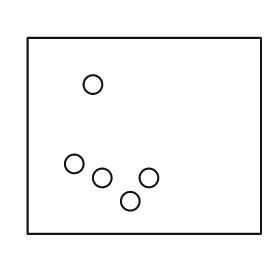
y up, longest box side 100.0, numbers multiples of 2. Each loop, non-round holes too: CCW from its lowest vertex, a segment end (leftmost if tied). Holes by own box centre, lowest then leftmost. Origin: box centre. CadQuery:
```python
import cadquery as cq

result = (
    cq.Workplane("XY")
    .moveTo(-50.0, -42.0)
    .lineTo(50.0, -42.0)
    .lineTo(50.0, 42.0)
    .lineTo(-50.0, 42.0)
    .close()
    .moveTo(-6.0, -28.0)
    .circle(4.0)
    .moveTo(-18.0, -18.0)
    .circle(4.0)
    .moveTo(2.0, -18.0)
    .circle(4.0)
    .moveTo(-30.0, -12.0)
    .circle(4.0)
    .moveTo(-22.0, 22.0)
    .circle(4.0)
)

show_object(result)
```